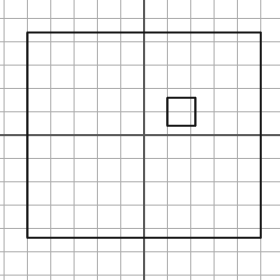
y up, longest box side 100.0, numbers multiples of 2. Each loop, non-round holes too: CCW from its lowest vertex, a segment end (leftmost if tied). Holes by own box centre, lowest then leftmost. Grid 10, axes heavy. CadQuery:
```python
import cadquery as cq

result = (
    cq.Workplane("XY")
    .moveTo(-50.0, -44.0)
    .lineTo(50.0, -44.0)
    .lineTo(50.0, 44.0)
    .lineTo(-50.0, 44.0)
    .close()
    .moveTo(10.0, 4.0)
    .lineTo(22.0, 4.0)
    .lineTo(22.0, 16.0)
    .lineTo(10.0, 16.0)
    .close()
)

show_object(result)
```